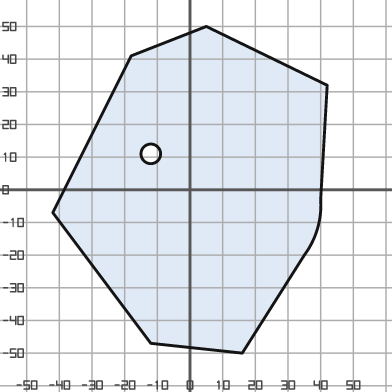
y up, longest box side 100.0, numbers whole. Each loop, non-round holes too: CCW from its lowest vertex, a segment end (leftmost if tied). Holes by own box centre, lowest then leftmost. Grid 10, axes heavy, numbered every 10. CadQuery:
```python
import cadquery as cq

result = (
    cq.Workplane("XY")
    .moveTo(16.0, -50.0)
    .lineTo(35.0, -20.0)
    .threePointArc((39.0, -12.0), (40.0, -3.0))
    .lineTo(42.0, 32.0)
    .lineTo(5.0, 50.0)
    .lineTo(-18.0, 41.0)
    .lineTo(-42.0, -7.0)
    .lineTo(-12.0, -47.0)
    .close()
    .moveTo(-12.0, 11.0)
    .circle(3.0)
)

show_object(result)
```